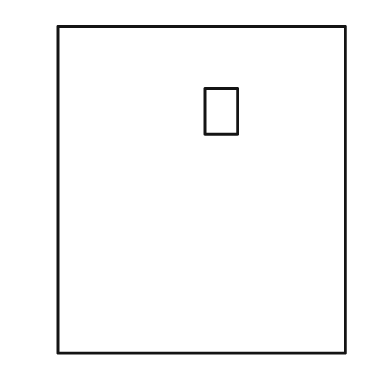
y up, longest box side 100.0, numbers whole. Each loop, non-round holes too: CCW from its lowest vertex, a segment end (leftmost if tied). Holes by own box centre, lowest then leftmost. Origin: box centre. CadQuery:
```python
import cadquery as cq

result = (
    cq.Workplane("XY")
    .moveTo(-44.0, -50.0)
    .lineTo(44.0, -50.0)
    .lineTo(44.0, 50.0)
    .lineTo(-44.0, 50.0)
    .close()
    .moveTo(1.0, 17.0)
    .lineTo(11.0, 17.0)
    .lineTo(11.0, 31.0)
    .lineTo(1.0, 31.0)
    .close()
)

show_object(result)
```